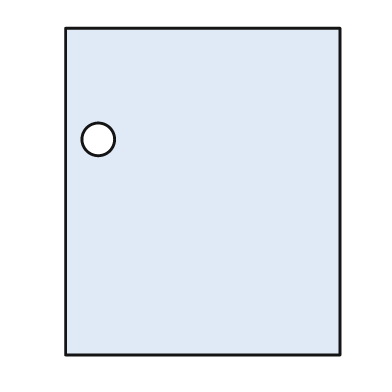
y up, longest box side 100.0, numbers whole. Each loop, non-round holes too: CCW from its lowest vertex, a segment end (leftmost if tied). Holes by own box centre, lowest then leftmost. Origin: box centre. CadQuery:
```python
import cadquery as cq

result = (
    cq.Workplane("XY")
    .moveTo(-42.0, -50.0)
    .lineTo(42.0, -50.0)
    .lineTo(42.0, 50.0)
    .lineTo(-42.0, 50.0)
    .close()
    .moveTo(-32.0, 16.0)
    .circle(5.0)
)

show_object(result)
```